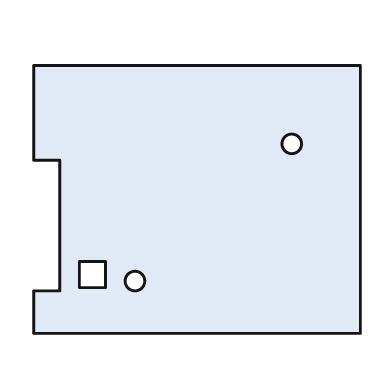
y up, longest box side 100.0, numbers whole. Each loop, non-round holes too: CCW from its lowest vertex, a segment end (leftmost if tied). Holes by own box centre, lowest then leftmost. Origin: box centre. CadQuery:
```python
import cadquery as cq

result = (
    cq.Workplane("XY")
    .moveTo(-50.0, -41.0)
    .lineTo(50.0, -41.0)
    .lineTo(50.0, 41.0)
    .lineTo(-50.0, 41.0)
    .lineTo(-50.0, 12.0)
    .lineTo(-42.0, 12.0)
    .lineTo(-42.0, -28.0)
    .lineTo(-50.0, -28.0)
    .close()
    .moveTo(-19.0, -25.0)
    .circle(3.0)
    .moveTo(-36.0, -27.0)
    .lineTo(-28.0, -27.0)
    .lineTo(-28.0, -19.0)
    .lineTo(-36.0, -19.0)
    .close()
    .moveTo(29.0, 17.0)
    .circle(3.0)
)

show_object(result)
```